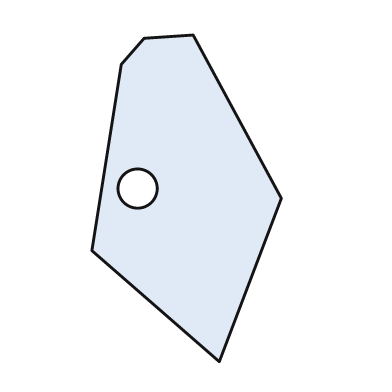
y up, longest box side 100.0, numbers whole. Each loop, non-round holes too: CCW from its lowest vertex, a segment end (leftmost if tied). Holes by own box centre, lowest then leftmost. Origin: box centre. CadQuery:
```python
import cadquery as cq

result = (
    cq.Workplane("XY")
    .moveTo(10.0, -50.0)
    .lineTo(29.0, 0.0)
    .lineTo(2.0, 50.0)
    .lineTo(-13.0, 49.0)
    .lineTo(-20.0, 41.0)
    .lineTo(-29.0, -16.0)
    .close()
    .moveTo(-15.0, 3.0)
    .circle(6.0)
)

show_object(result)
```